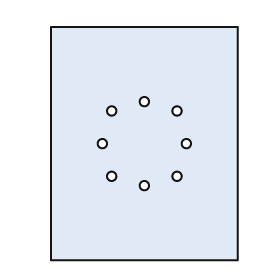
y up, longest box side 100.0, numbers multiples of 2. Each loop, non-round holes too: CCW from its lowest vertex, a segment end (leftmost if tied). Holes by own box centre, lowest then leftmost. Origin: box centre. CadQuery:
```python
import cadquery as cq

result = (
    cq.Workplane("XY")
    .moveTo(-40.0, -50.0)
    .lineTo(40.0, -50.0)
    .lineTo(40.0, 50.0)
    .lineTo(-40.0, 50.0)
    .close()
    .moveTo(0.0, -18.0)
    .circle(2.0)
    .moveTo(-14.0, -14.0)
    .circle(2.0)
    .moveTo(14.0, -14.0)
    .circle(2.0)
    .moveTo(-18.0, 0.0)
    .circle(2.0)
    .moveTo(18.0, 0.0)
    .circle(2.0)
    .moveTo(-14.0, 14.0)
    .circle(2.0)
    .moveTo(14.0, 14.0)
    .circle(2.0)
    .moveTo(0.0, 18.0)
    .circle(2.0)
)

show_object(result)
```